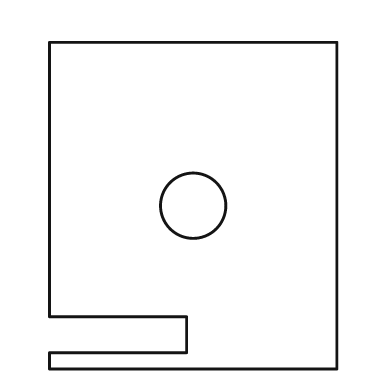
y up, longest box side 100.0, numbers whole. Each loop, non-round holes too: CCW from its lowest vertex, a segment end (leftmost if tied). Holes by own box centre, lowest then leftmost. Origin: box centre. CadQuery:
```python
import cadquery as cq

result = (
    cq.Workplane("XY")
    .moveTo(-44.0, -50.0)
    .lineTo(44.0, -50.0)
    .lineTo(44.0, 50.0)
    .lineTo(-44.0, 50.0)
    .lineTo(-44.0, -34.0)
    .lineTo(-2.0, -34.0)
    .lineTo(-2.0, -45.0)
    .lineTo(-44.0, -45.0)
    .close()
    .moveTo(0.0, 0.0)
    .circle(10.0)
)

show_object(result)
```